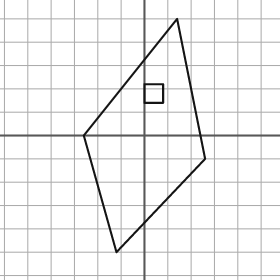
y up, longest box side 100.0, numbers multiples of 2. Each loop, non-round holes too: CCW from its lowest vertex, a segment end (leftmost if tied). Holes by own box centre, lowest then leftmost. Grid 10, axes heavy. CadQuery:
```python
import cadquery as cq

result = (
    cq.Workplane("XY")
    .moveTo(-12.0, -50.0)
    .lineTo(26.0, -10.0)
    .lineTo(14.0, 50.0)
    .lineTo(-26.0, 0.0)
    .close()
    .moveTo(0.0, 14.0)
    .lineTo(8.0, 14.0)
    .lineTo(8.0, 22.0)
    .lineTo(0.0, 22.0)
    .close()
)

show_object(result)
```